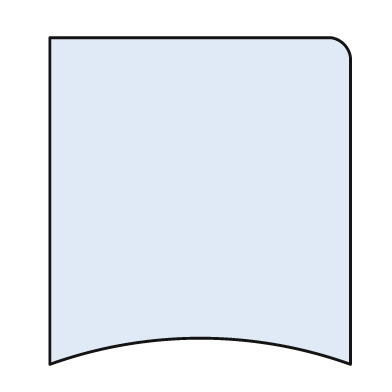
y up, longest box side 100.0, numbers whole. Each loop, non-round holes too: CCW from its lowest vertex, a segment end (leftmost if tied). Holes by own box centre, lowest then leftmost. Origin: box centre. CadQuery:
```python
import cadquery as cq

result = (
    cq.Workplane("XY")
    .moveTo(-46.0, -50.0)
    .threePointArc((0.0, -42.0), (46.0, -50.0))
    .lineTo(46.0, 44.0)
    .threePointArc((44.0, 48.0), (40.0, 50.0))
    .lineTo(-46.0, 50.0)
    .close()
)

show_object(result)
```